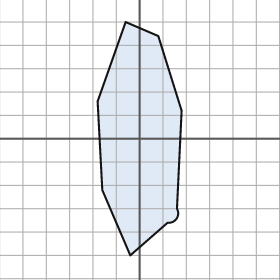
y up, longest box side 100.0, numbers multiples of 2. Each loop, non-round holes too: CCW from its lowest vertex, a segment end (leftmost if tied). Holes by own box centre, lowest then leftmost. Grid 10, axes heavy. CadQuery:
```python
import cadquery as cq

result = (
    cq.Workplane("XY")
    .moveTo(-4.0, -50.0)
    .lineTo(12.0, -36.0)
    .threePointArc((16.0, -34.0), (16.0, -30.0))
    .lineTo(18.0, 12.0)
    .lineTo(8.0, 44.0)
    .lineTo(-6.0, 50.0)
    .lineTo(-18.0, 16.0)
    .lineTo(-16.0, -22.0)
    .close()
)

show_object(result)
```